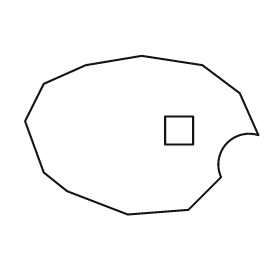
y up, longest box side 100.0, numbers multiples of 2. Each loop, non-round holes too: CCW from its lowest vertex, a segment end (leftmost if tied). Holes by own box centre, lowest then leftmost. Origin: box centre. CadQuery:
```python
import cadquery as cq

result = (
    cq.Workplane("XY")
    .moveTo(-6.0, -34.0)
    .lineTo(20.0, -32.0)
    .lineTo(34.0, -18.0)
    .threePointArc((36.0, -4.0), (50.0, 0.0))
    .lineTo(42.0, 18.0)
    .lineTo(26.0, 30.0)
    .lineTo(0.0, 34.0)
    .lineTo(-24.0, 30.0)
    .lineTo(-42.0, 22.0)
    .lineTo(-50.0, 6.0)
    .lineTo(-42.0, -16.0)
    .lineTo(-32.0, -24.0)
    .close()
    .moveTo(10.0, -4.0)
    .lineTo(22.0, -4.0)
    .lineTo(22.0, 8.0)
    .lineTo(10.0, 8.0)
    .close()
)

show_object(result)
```